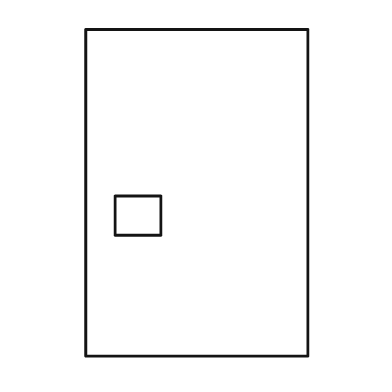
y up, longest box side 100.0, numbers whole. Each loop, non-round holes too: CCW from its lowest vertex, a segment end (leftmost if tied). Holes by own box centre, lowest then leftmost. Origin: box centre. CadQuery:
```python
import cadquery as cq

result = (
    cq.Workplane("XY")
    .moveTo(-34.0, -50.0)
    .lineTo(34.0, -50.0)
    .lineTo(34.0, 50.0)
    .lineTo(-34.0, 50.0)
    .close()
    .moveTo(-25.0, -13.0)
    .lineTo(-11.0, -13.0)
    .lineTo(-11.0, -1.0)
    .lineTo(-25.0, -1.0)
    .close()
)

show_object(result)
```